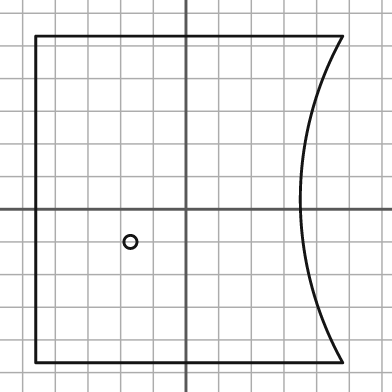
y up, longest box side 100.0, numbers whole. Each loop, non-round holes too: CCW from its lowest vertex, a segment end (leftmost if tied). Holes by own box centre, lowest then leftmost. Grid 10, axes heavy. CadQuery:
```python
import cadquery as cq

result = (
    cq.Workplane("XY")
    .moveTo(-46.0, -47.0)
    .lineTo(48.0, -47.0)
    .threePointArc((35.0, 3.0), (48.0, 53.0))
    .lineTo(-46.0, 53.0)
    .close()
    .moveTo(-17.0, -10.0)
    .circle(2.0)
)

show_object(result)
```